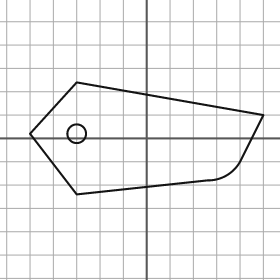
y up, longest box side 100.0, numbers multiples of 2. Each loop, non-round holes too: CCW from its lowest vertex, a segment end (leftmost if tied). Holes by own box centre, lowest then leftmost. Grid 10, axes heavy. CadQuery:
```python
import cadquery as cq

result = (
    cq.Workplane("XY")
    .moveTo(-30.0, -24.0)
    .lineTo(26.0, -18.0)
    .threePointArc((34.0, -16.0), (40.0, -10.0))
    .lineTo(50.0, 10.0)
    .lineTo(-30.0, 24.0)
    .lineTo(-50.0, 2.0)
    .close()
    .moveTo(-30.0, 2.0)
    .circle(4.0)
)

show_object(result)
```